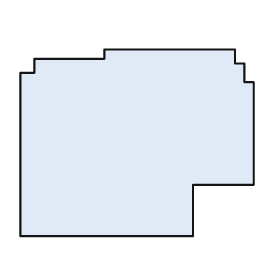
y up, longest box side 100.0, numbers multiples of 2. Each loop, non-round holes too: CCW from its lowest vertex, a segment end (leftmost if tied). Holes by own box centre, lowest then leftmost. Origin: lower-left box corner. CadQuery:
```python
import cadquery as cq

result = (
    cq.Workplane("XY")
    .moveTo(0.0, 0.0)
    .lineTo(74.0, 0.0)
    .lineTo(74.0, 22.0)
    .lineTo(100.0, 22.0)
    .lineTo(100.0, 66.0)
    .lineTo(96.0, 66.0)
    .lineTo(96.0, 74.0)
    .lineTo(92.0, 74.0)
    .lineTo(92.0, 80.0)
    .lineTo(36.0, 80.0)
    .lineTo(36.0, 76.0)
    .lineTo(6.0, 76.0)
    .lineTo(6.0, 70.0)
    .lineTo(0.0, 70.0)
    .close()
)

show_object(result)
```